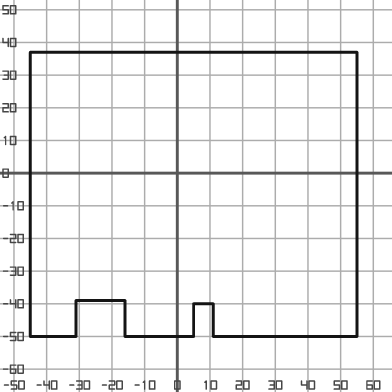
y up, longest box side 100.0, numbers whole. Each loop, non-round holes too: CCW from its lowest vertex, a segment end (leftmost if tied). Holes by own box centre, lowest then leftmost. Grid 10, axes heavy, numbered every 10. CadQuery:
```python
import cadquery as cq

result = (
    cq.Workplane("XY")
    .moveTo(-45.0, -50.0)
    .lineTo(-31.0, -50.0)
    .lineTo(-31.0, -39.0)
    .lineTo(-16.0, -39.0)
    .lineTo(-16.0, -50.0)
    .lineTo(5.0, -50.0)
    .lineTo(5.0, -40.0)
    .lineTo(11.0, -40.0)
    .lineTo(11.0, -50.0)
    .lineTo(55.0, -50.0)
    .lineTo(55.0, 37.0)
    .lineTo(-45.0, 37.0)
    .close()
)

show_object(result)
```